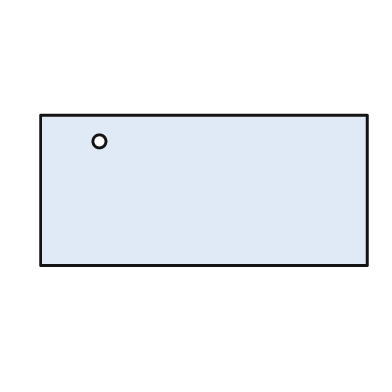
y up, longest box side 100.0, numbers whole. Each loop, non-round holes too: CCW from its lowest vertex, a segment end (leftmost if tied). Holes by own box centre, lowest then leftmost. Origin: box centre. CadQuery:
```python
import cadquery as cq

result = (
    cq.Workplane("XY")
    .moveTo(-50.0, -23.0)
    .lineTo(50.0, -23.0)
    .lineTo(50.0, 23.0)
    .lineTo(-50.0, 23.0)
    .close()
    .moveTo(-32.0, 15.0)
    .circle(2.0)
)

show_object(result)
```